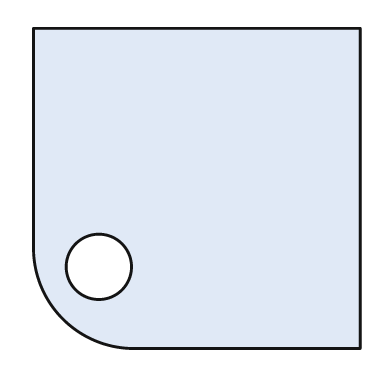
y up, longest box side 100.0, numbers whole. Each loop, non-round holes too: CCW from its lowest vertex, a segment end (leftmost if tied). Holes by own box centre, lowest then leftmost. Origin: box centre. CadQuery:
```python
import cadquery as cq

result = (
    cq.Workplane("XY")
    .moveTo(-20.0, -49.0)
    .lineTo(50.0, -49.0)
    .lineTo(50.0, 49.0)
    .lineTo(-50.0, 49.0)
    .lineTo(-50.0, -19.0)
    .threePointArc((-41.0, -40.0), (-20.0, -49.0))
    .close()
    .moveTo(-30.0, -24.0)
    .circle(10.0)
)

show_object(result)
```